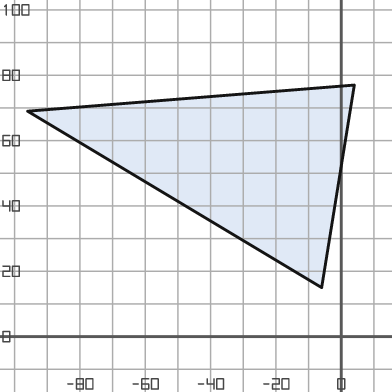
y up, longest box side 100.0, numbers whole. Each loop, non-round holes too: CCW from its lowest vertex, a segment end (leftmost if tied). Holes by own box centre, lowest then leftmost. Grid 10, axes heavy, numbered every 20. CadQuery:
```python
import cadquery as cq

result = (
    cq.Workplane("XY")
    .moveTo(-6.0, 15.0)
    .lineTo(4.0, 77.0)
    .lineTo(-96.0, 69.0)
    .close()
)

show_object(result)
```